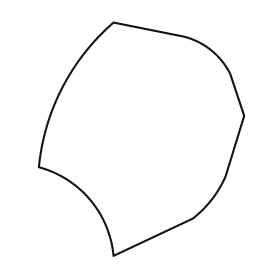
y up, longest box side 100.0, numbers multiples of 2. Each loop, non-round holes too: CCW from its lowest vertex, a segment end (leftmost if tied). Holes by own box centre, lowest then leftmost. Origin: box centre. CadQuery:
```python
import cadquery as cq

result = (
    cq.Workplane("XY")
    .moveTo(-12.0, -50.0)
    .lineTo(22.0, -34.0)
    .threePointArc((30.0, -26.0), (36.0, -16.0))
    .lineTo(44.0, 10.0)
    .lineTo(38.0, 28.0)
    .threePointArc((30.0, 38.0), (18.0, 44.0))
    .lineTo(-12.0, 50.0)
    .threePointArc((-34.0, 22.0), (-44.0, -12.0))
    .threePointArc((-22.0, -26.0), (-12.0, -50.0))
    .close()
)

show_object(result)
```